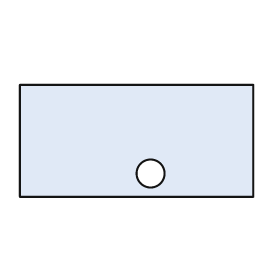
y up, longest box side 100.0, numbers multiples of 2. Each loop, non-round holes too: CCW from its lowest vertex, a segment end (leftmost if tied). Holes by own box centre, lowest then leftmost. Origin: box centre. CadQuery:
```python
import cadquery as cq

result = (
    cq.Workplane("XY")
    .moveTo(-50.0, -24.0)
    .lineTo(50.0, -24.0)
    .lineTo(50.0, 24.0)
    .lineTo(-50.0, 24.0)
    .close()
    .moveTo(6.0, -14.0)
    .circle(6.0)
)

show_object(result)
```